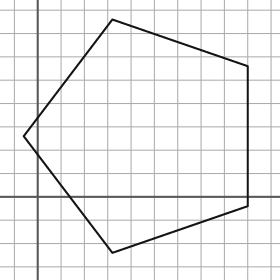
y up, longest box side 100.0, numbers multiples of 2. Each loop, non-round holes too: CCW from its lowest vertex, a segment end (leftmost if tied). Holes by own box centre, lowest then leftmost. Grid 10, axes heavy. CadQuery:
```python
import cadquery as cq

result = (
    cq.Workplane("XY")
    .moveTo(32.0, -24.0)
    .lineTo(90.0, -4.0)
    .lineTo(90.0, 56.0)
    .lineTo(32.0, 76.0)
    .lineTo(-6.0, 26.0)
    .close()
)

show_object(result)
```